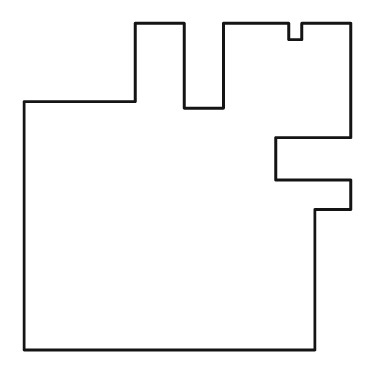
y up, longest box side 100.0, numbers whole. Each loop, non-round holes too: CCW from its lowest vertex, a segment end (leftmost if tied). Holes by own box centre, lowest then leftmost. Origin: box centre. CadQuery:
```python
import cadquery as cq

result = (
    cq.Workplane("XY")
    .moveTo(-50.0, -50.0)
    .lineTo(39.0, -50.0)
    .lineTo(39.0, -7.0)
    .lineTo(50.0, -7.0)
    .lineTo(50.0, 2.0)
    .lineTo(27.0, 2.0)
    .lineTo(27.0, 15.0)
    .lineTo(50.0, 15.0)
    .lineTo(50.0, 50.0)
    .lineTo(35.0, 50.0)
    .lineTo(35.0, 45.0)
    .lineTo(31.0, 45.0)
    .lineTo(31.0, 50.0)
    .lineTo(11.0, 50.0)
    .lineTo(11.0, 24.0)
    .lineTo(-1.0, 24.0)
    .lineTo(-1.0, 50.0)
    .lineTo(-16.0, 50.0)
    .lineTo(-16.0, 26.0)
    .lineTo(-50.0, 26.0)
    .close()
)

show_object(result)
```